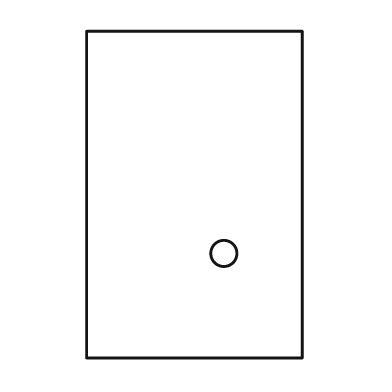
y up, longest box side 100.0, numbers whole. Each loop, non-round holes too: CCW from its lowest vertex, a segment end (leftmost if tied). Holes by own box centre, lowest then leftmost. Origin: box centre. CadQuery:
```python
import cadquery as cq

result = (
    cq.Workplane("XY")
    .moveTo(-33.0, -50.0)
    .lineTo(33.0, -50.0)
    .lineTo(33.0, 50.0)
    .lineTo(-33.0, 50.0)
    .close()
    .moveTo(9.0, -18.0)
    .circle(4.0)
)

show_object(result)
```